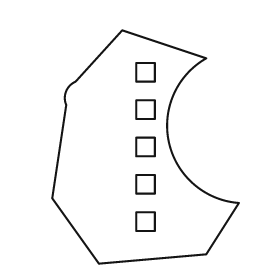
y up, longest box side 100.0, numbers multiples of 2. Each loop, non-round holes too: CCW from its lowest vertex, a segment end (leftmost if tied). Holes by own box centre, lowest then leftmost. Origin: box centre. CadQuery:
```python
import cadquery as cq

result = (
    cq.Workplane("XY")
    .moveTo(-20.0, -50.0)
    .lineTo(26.0, -46.0)
    .lineTo(40.0, -24.0)
    .threePointArc((10.0, 2.0), (26.0, 38.0))
    .lineTo(-10.0, 50.0)
    .lineTo(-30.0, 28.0)
    .threePointArc((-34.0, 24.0), (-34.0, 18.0))
    .lineTo(-40.0, -22.0)
    .close()
    .moveTo(-4.0, -36.0)
    .lineTo(4.0, -36.0)
    .lineTo(4.0, -28.0)
    .lineTo(-4.0, -28.0)
    .close()
    .moveTo(-4.0, -20.0)
    .lineTo(4.0, -20.0)
    .lineTo(4.0, -12.0)
    .lineTo(-4.0, -12.0)
    .close()
    .moveTo(-4.0, -4.0)
    .lineTo(4.0, -4.0)
    .lineTo(4.0, 4.0)
    .lineTo(-4.0, 4.0)
    .close()
    .moveTo(-4.0, 12.0)
    .lineTo(4.0, 12.0)
    .lineTo(4.0, 20.0)
    .lineTo(-4.0, 20.0)
    .close()
    .moveTo(-4.0, 28.0)
    .lineTo(4.0, 28.0)
    .lineTo(4.0, 36.0)
    .lineTo(-4.0, 36.0)
    .close()
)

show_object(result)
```